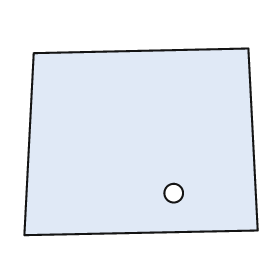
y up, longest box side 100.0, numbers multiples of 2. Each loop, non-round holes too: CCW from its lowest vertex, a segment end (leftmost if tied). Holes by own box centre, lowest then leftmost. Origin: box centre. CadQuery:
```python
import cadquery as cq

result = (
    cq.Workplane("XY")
    .moveTo(-50.0, -40.0)
    .lineTo(50.0, -38.0)
    .lineTo(46.0, 40.0)
    .lineTo(-46.0, 38.0)
    .close()
    .moveTo(14.0, -22.0)
    .circle(4.0)
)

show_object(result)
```